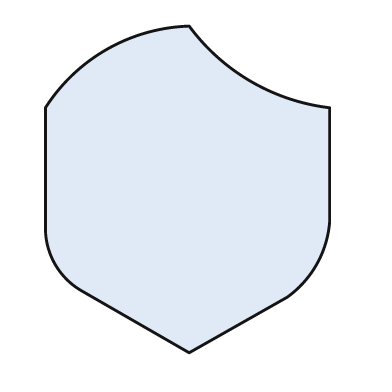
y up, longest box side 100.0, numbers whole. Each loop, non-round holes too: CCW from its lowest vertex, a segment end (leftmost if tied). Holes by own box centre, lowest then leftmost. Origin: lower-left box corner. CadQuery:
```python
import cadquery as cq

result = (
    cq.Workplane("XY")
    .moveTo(44.0, 0.0)
    .lineTo(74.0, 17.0)
    .threePointArc((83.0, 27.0), (87.0, 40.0))
    .lineTo(87.0, 75.0)
    .threePointArc((63.0, 83.0), (44.0, 100.0))
    .threePointArc((19.0, 93.0), (0.0, 75.0))
    .lineTo(0.0, 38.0)
    .threePointArc((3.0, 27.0), (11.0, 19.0))
    .close()
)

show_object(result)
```